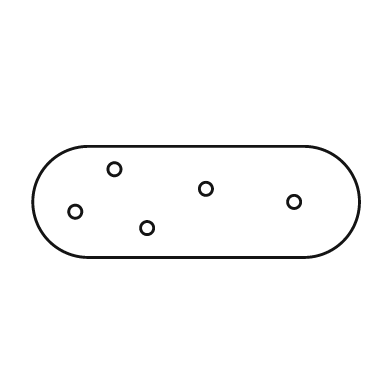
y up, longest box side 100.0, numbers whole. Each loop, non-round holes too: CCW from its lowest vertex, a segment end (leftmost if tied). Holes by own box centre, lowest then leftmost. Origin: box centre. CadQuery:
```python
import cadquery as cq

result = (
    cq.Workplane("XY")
    .moveTo(-33.0, -17.0)
    .lineTo(33.0, -17.0)
    .threePointArc((50.0, 0.0), (33.0, 17.0))
    .lineTo(-33.0, 17.0)
    .threePointArc((-50.0, 0.0), (-33.0, -17.0))
    .close()
    .moveTo(-15.0, -8.0)
    .circle(2.0)
    .moveTo(-37.0, -3.0)
    .circle(2.0)
    .moveTo(30.0, 0.0)
    .circle(2.0)
    .moveTo(3.0, 4.0)
    .circle(2.0)
    .moveTo(-25.0, 10.0)
    .circle(2.0)
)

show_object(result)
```